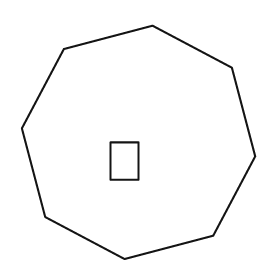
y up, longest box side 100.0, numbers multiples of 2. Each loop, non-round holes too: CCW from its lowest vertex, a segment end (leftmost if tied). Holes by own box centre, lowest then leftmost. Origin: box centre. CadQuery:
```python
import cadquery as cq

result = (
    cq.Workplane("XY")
    .moveTo(-6.0, -50.0)
    .lineTo(32.0, -40.0)
    .lineTo(50.0, -6.0)
    .lineTo(40.0, 32.0)
    .lineTo(6.0, 50.0)
    .lineTo(-32.0, 40.0)
    .lineTo(-50.0, 6.0)
    .lineTo(-40.0, -32.0)
    .close()
    .moveTo(-12.0, -16.0)
    .lineTo(0.0, -16.0)
    .lineTo(0.0, 0.0)
    .lineTo(-12.0, 0.0)
    .close()
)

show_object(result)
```